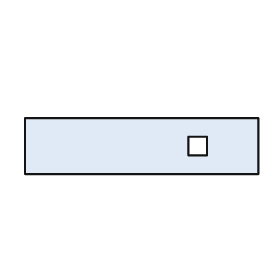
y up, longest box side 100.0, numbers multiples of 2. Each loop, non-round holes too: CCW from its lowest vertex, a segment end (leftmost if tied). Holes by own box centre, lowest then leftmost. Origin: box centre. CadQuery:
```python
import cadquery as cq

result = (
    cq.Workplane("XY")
    .moveTo(-50.0, -12.0)
    .lineTo(50.0, -12.0)
    .lineTo(50.0, 12.0)
    .lineTo(-50.0, 12.0)
    .close()
    .moveTo(20.0, -4.0)
    .lineTo(28.0, -4.0)
    .lineTo(28.0, 4.0)
    .lineTo(20.0, 4.0)
    .close()
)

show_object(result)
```